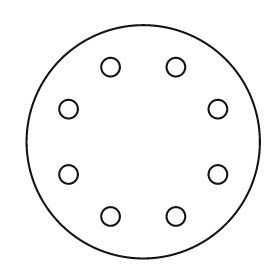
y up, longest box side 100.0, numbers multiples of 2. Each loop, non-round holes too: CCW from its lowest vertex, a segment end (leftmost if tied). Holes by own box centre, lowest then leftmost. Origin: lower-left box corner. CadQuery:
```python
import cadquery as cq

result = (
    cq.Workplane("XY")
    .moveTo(50.0, 50.0)
    .circle(50.0)
    .moveTo(36.0, 18.0)
    .circle(4.0)
    .moveTo(64.0, 18.0)
    .circle(4.0)
    .moveTo(18.0, 36.0)
    .circle(4.0)
    .moveTo(82.0, 36.0)
    .circle(4.0)
    .moveTo(18.0, 64.0)
    .circle(4.0)
    .moveTo(82.0, 64.0)
    .circle(4.0)
    .moveTo(36.0, 82.0)
    .circle(4.0)
    .moveTo(64.0, 82.0)
    .circle(4.0)
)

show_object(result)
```